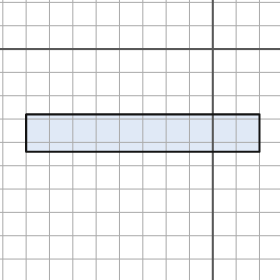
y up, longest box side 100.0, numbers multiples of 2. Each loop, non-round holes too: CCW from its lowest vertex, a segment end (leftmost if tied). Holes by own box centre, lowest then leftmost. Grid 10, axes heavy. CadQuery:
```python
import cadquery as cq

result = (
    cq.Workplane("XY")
    .moveTo(-80.0, -44.0)
    .lineTo(20.0, -44.0)
    .lineTo(20.0, -28.0)
    .lineTo(-80.0, -28.0)
    .close()
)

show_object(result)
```